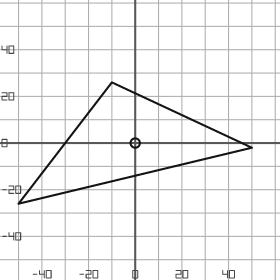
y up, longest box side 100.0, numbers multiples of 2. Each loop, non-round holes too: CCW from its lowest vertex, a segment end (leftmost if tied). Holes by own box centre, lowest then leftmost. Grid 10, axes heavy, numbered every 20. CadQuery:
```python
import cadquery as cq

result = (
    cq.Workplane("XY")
    .moveTo(-50.0, -26.0)
    .lineTo(50.0, -2.0)
    .lineTo(-10.0, 26.0)
    .close()
    .moveTo(0.0, 0.0)
    .circle(2.0)
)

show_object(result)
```